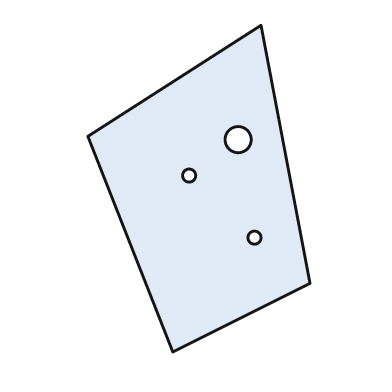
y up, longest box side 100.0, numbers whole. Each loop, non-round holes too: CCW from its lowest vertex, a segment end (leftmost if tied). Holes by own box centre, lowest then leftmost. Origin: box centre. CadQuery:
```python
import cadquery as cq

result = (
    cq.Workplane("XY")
    .moveTo(-8.0, -50.0)
    .lineTo(34.0, -29.0)
    .lineTo(19.0, 50.0)
    .lineTo(-34.0, 16.0)
    .close()
    .moveTo(17.0, -15.0)
    .circle(2.0)
    .moveTo(-3.0, 4.0)
    .circle(2.0)
    .moveTo(12.0, 15.0)
    .circle(4.0)
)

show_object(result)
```